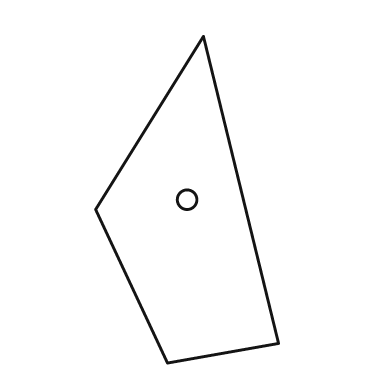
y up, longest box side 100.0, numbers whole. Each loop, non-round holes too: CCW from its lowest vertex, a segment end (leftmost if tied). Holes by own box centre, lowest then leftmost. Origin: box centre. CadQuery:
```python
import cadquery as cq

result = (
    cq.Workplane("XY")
    .moveTo(-6.0, -50.0)
    .lineTo(28.0, -44.0)
    .lineTo(5.0, 50.0)
    .lineTo(-28.0, -3.0)
    .close()
    .moveTo(0.0, 0.0)
    .circle(3.0)
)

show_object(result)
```